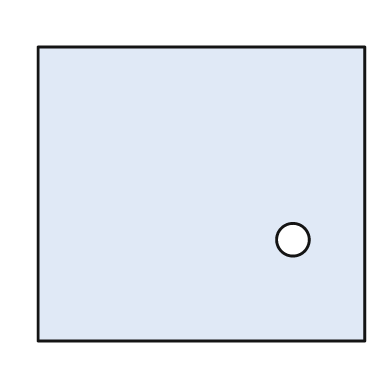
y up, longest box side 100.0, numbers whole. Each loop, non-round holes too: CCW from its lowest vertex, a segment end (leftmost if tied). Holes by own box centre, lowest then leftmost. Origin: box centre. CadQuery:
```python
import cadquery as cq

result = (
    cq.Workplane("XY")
    .moveTo(-50.0, -45.0)
    .lineTo(50.0, -45.0)
    .lineTo(50.0, 45.0)
    .lineTo(-50.0, 45.0)
    .close()
    .moveTo(28.0, -14.0)
    .circle(5.0)
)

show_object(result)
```